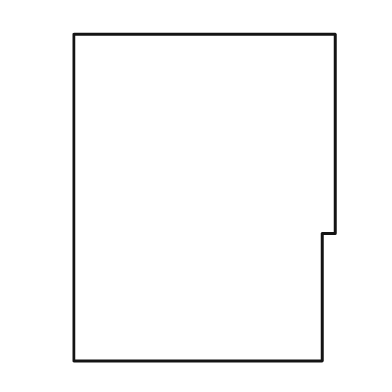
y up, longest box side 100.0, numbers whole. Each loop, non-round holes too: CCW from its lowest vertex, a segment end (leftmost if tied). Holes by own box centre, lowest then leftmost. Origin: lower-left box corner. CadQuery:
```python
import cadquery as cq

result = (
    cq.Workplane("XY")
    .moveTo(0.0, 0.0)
    .lineTo(76.0, 0.0)
    .lineTo(76.0, 39.0)
    .lineTo(80.0, 39.0)
    .lineTo(80.0, 100.0)
    .lineTo(0.0, 100.0)
    .close()
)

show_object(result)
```